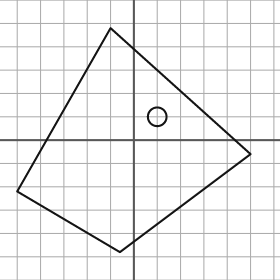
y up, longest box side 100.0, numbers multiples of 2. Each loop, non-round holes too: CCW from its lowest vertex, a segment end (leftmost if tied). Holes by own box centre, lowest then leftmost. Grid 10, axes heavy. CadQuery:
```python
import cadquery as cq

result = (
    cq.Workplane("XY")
    .moveTo(-6.0, -48.0)
    .lineTo(50.0, -6.0)
    .lineTo(-10.0, 48.0)
    .lineTo(-50.0, -22.0)
    .close()
    .moveTo(10.0, 10.0)
    .circle(4.0)
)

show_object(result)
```